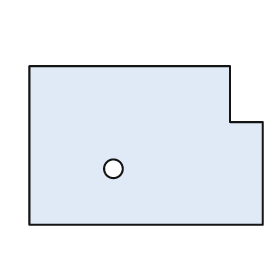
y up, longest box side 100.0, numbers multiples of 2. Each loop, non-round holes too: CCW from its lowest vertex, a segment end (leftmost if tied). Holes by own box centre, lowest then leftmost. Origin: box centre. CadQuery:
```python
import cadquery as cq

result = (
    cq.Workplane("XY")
    .moveTo(-50.0, -34.0)
    .lineTo(50.0, -34.0)
    .lineTo(50.0, 10.0)
    .lineTo(36.0, 10.0)
    .lineTo(36.0, 34.0)
    .lineTo(-50.0, 34.0)
    .close()
    .moveTo(-14.0, -10.0)
    .circle(4.0)
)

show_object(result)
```